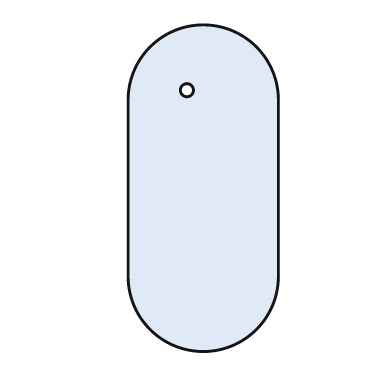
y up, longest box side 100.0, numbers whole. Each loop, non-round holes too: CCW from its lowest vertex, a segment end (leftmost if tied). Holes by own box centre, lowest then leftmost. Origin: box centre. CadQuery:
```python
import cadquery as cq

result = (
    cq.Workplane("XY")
    .moveTo(-23.0, -27.0)
    .threePointArc((0.0, -50.0), (23.0, -27.0))
    .lineTo(23.0, 27.0)
    .threePointArc((0.0, 50.0), (-23.0, 27.0))
    .close()
    .moveTo(-5.0, 30.0)
    .circle(2.0)
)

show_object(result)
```